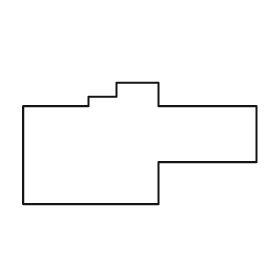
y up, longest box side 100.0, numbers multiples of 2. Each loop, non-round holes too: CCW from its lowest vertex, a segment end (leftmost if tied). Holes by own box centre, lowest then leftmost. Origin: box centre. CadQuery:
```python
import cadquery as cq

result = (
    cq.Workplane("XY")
    .moveTo(-50.0, -26.0)
    .lineTo(8.0, -26.0)
    .lineTo(8.0, -8.0)
    .lineTo(50.0, -8.0)
    .lineTo(50.0, 16.0)
    .lineTo(8.0, 16.0)
    .lineTo(8.0, 26.0)
    .lineTo(-10.0, 26.0)
    .lineTo(-10.0, 20.0)
    .lineTo(-22.0, 20.0)
    .lineTo(-22.0, 16.0)
    .lineTo(-50.0, 16.0)
    .close()
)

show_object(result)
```